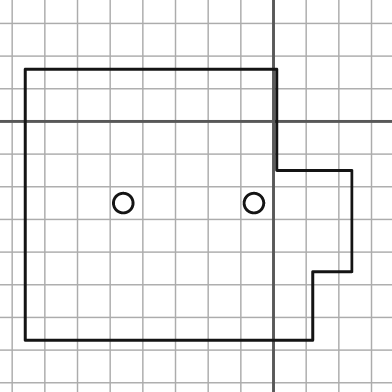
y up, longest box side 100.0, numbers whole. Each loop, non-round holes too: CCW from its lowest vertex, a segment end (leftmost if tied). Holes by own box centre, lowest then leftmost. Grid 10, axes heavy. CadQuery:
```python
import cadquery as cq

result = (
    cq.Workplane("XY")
    .moveTo(-76.0, -67.0)
    .lineTo(12.0, -67.0)
    .lineTo(12.0, -46.0)
    .lineTo(24.0, -46.0)
    .lineTo(24.0, -15.0)
    .lineTo(1.0, -15.0)
    .lineTo(1.0, 16.0)
    .lineTo(-76.0, 16.0)
    .close()
    .moveTo(-46.0, -25.0)
    .circle(3.0)
    .moveTo(-6.0, -25.0)
    .circle(3.0)
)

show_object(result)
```